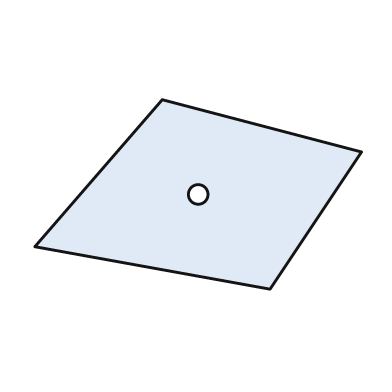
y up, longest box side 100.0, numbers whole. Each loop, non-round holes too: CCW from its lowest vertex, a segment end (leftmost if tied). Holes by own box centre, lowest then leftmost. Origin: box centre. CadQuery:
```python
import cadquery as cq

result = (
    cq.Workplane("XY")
    .moveTo(22.0, -29.0)
    .lineTo(50.0, 13.0)
    .lineTo(-11.0, 29.0)
    .lineTo(-50.0, -16.0)
    .close()
    .moveTo(0.0, 0.0)
    .circle(3.0)
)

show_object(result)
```